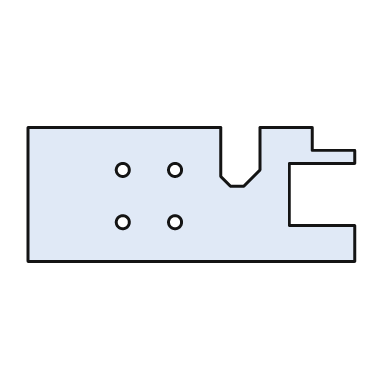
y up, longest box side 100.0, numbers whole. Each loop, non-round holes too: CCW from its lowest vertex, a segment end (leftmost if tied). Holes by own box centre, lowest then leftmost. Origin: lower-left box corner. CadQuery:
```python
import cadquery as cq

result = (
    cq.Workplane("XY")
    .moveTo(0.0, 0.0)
    .lineTo(100.0, 0.0)
    .lineTo(100.0, 11.0)
    .lineTo(80.0, 11.0)
    .lineTo(80.0, 30.0)
    .lineTo(100.0, 30.0)
    .lineTo(100.0, 34.0)
    .lineTo(87.0, 34.0)
    .lineTo(87.0, 41.0)
    .lineTo(71.0, 41.0)
    .lineTo(71.0, 28.0)
    .lineTo(66.0, 23.0)
    .lineTo(62.0, 23.0)
    .lineTo(59.0, 26.0)
    .lineTo(59.0, 41.0)
    .lineTo(0.0, 41.0)
    .close()
    .moveTo(29.0, 12.0)
    .circle(2.0)
    .moveTo(45.0, 12.0)
    .circle(2.0)
    .moveTo(29.0, 28.0)
    .circle(2.0)
    .moveTo(45.0, 28.0)
    .circle(2.0)
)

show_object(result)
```